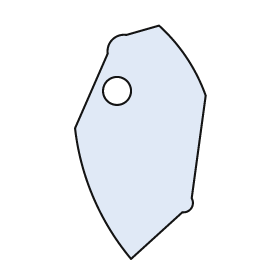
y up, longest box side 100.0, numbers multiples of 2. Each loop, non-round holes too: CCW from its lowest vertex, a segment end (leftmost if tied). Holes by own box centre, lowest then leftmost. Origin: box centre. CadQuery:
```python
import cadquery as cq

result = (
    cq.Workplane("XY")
    .moveTo(-4.0, -50.0)
    .lineTo(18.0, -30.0)
    .threePointArc((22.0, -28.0), (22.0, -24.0))
    .lineTo(28.0, 20.0)
    .threePointArc((20.0, 36.0), (8.0, 50.0))
    .lineTo(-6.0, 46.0)
    .threePointArc((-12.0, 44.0), (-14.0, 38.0))
    .lineTo(-28.0, 6.0)
    .threePointArc((-20.0, -24.0), (-4.0, -50.0))
    .close()
    .moveTo(-10.0, 22.0)
    .circle(6.0)
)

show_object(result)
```